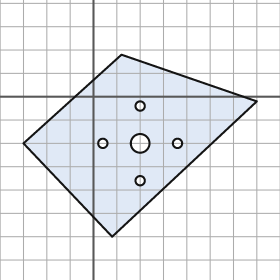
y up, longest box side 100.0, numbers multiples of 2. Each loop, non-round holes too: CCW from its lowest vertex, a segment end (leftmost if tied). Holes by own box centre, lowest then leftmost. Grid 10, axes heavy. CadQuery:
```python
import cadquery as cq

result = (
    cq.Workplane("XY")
    .moveTo(8.0, -60.0)
    .lineTo(70.0, -2.0)
    .lineTo(12.0, 18.0)
    .lineTo(-30.0, -20.0)
    .close()
    .moveTo(20.0, -36.0)
    .circle(2.0)
    .moveTo(4.0, -20.0)
    .circle(2.0)
    .moveTo(20.0, -20.0)
    .circle(4.0)
    .moveTo(36.0, -20.0)
    .circle(2.0)
    .moveTo(20.0, -4.0)
    .circle(2.0)
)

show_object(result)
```